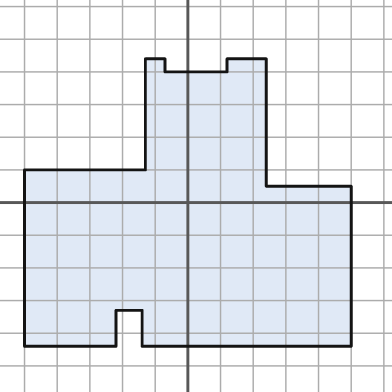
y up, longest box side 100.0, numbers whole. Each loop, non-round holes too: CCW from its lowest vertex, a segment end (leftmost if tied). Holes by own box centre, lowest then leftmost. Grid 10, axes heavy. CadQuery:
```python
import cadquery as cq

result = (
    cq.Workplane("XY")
    .moveTo(-50.0, -44.0)
    .lineTo(-22.0, -44.0)
    .lineTo(-22.0, -33.0)
    .lineTo(-14.0, -33.0)
    .lineTo(-14.0, -44.0)
    .lineTo(50.0, -44.0)
    .lineTo(50.0, 5.0)
    .lineTo(24.0, 5.0)
    .lineTo(24.0, 44.0)
    .lineTo(12.0, 44.0)
    .lineTo(12.0, 40.0)
    .lineTo(-7.0, 40.0)
    .lineTo(-7.0, 44.0)
    .lineTo(-13.0, 44.0)
    .lineTo(-13.0, 10.0)
    .lineTo(-50.0, 10.0)
    .close()
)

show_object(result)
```